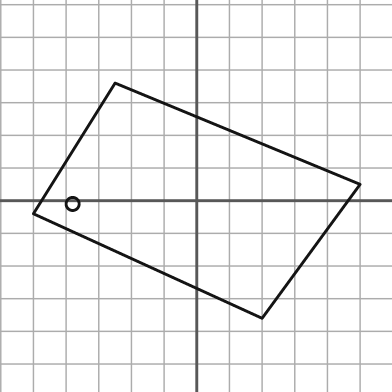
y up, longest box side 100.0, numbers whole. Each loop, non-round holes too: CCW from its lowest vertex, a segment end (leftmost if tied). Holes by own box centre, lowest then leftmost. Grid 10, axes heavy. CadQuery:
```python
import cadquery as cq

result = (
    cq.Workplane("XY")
    .moveTo(20.0, -36.0)
    .lineTo(50.0, 5.0)
    .lineTo(-25.0, 36.0)
    .lineTo(-50.0, -4.0)
    .close()
    .moveTo(-38.0, -1.0)
    .circle(2.0)
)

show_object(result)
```